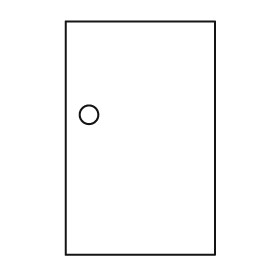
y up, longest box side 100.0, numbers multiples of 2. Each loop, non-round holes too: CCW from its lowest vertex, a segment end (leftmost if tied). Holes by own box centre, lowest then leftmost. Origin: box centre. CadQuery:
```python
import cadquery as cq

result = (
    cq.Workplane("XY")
    .moveTo(-32.0, -50.0)
    .lineTo(32.0, -50.0)
    .lineTo(32.0, 50.0)
    .lineTo(-32.0, 50.0)
    .close()
    .moveTo(-22.0, 10.0)
    .circle(4.0)
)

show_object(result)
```